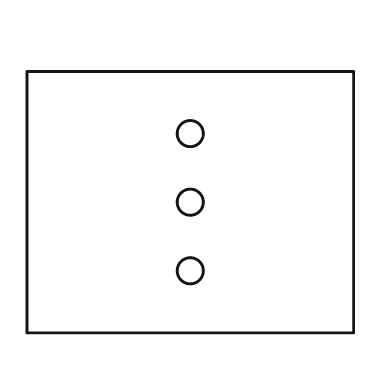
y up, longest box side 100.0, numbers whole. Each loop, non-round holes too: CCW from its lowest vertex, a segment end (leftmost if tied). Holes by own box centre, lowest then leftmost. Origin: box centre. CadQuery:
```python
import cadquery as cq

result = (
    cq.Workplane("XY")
    .moveTo(-50.0, -40.0)
    .lineTo(50.0, -40.0)
    .lineTo(50.0, 40.0)
    .lineTo(-50.0, 40.0)
    .close()
    .moveTo(0.0, -21.0)
    .circle(4.0)
    .moveTo(0.0, 0.0)
    .circle(4.0)
    .moveTo(0.0, 21.0)
    .circle(4.0)
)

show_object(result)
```